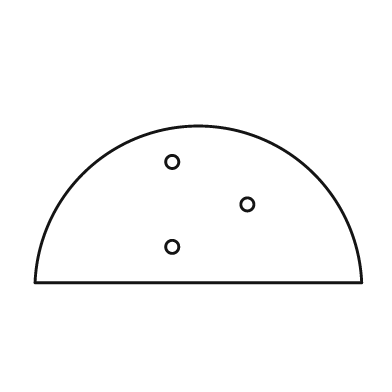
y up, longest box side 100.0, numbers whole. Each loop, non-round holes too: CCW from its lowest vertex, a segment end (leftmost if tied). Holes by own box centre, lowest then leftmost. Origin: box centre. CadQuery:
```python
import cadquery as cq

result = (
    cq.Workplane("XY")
    .moveTo(-50.0, -24.0)
    .lineTo(50.0, -24.0)
    .threePointArc((0.0, 24.0), (-50.0, -24.0))
    .close()
    .moveTo(-8.0, -13.0)
    .circle(2.0)
    .moveTo(15.0, 0.0)
    .circle(2.0)
    .moveTo(-8.0, 13.0)
    .circle(2.0)
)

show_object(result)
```